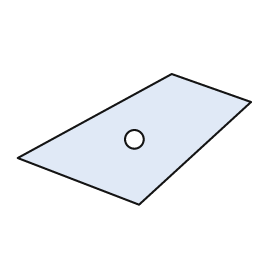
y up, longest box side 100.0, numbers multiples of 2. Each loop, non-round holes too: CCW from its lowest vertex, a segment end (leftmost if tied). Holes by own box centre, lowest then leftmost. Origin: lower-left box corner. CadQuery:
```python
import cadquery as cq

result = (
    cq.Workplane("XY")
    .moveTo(52.0, 0.0)
    .lineTo(100.0, 44.0)
    .lineTo(66.0, 56.0)
    .lineTo(0.0, 20.0)
    .close()
    .moveTo(50.0, 28.0)
    .circle(4.0)
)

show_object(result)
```